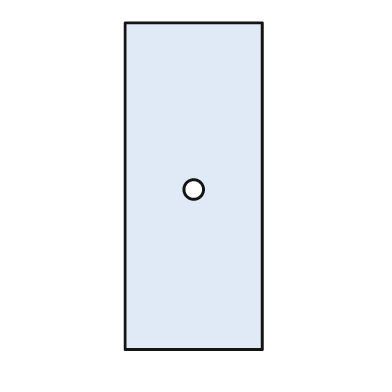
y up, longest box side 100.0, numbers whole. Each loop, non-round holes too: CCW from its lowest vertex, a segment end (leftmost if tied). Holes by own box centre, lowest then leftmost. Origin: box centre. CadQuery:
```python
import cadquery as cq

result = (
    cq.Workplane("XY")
    .moveTo(-21.0, -50.0)
    .lineTo(21.0, -50.0)
    .lineTo(21.0, 50.0)
    .lineTo(-21.0, 50.0)
    .close()
    .moveTo(0.0, -1.0)
    .circle(3.0)
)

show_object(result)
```